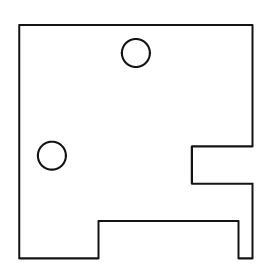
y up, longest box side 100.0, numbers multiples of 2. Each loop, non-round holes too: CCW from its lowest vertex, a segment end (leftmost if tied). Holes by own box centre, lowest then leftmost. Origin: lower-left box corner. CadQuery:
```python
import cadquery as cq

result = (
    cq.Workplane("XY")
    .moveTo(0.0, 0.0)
    .lineTo(34.0, 0.0)
    .lineTo(34.0, 16.0)
    .lineTo(94.0, 16.0)
    .lineTo(94.0, 0.0)
    .lineTo(100.0, 0.0)
    .lineTo(100.0, 32.0)
    .lineTo(74.0, 32.0)
    .lineTo(74.0, 48.0)
    .lineTo(100.0, 48.0)
    .lineTo(100.0, 100.0)
    .lineTo(0.0, 100.0)
    .close()
    .moveTo(14.0, 44.0)
    .circle(6.0)
    .moveTo(50.0, 88.0)
    .circle(6.0)
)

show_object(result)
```